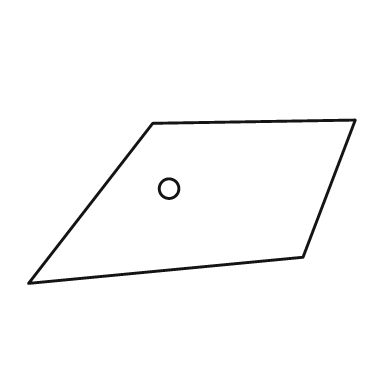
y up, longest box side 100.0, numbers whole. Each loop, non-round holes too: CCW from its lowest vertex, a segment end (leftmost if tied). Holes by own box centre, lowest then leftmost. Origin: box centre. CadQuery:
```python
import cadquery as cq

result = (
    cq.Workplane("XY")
    .moveTo(-50.0, -25.0)
    .lineTo(34.0, -17.0)
    .lineTo(50.0, 25.0)
    .lineTo(-12.0, 24.0)
    .close()
    .moveTo(-7.0, 4.0)
    .circle(3.0)
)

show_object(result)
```